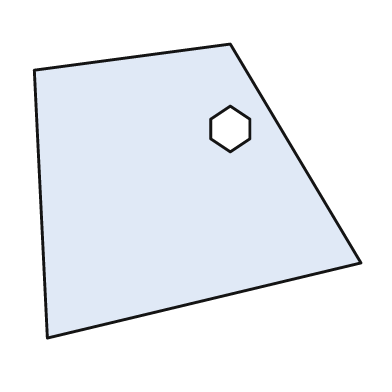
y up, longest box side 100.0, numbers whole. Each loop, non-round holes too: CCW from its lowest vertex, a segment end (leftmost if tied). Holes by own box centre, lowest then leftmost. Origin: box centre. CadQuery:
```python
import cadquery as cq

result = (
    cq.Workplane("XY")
    .moveTo(-46.0, -45.0)
    .lineTo(50.0, -22.0)
    .lineTo(10.0, 45.0)
    .lineTo(-50.0, 37.0)
    .close()
    .moveTo(10.0, 12.0)
    .lineTo(16.0, 16.0)
    .lineTo(16.0, 22.0)
    .lineTo(10.0, 26.0)
    .lineTo(4.0, 22.0)
    .lineTo(4.0, 16.0)
    .close()
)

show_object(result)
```